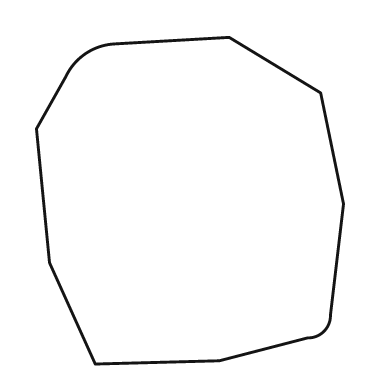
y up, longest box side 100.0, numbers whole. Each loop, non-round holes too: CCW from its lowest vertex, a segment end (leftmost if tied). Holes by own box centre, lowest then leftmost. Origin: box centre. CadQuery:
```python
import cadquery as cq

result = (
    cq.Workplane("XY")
    .moveTo(-29.0, -50.0)
    .lineTo(9.0, -49.0)
    .lineTo(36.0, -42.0)
    .threePointArc((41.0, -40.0), (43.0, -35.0))
    .lineTo(47.0, -1.0)
    .lineTo(40.0, 33.0)
    .lineTo(12.0, 50.0)
    .lineTo(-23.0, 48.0)
    .threePointArc((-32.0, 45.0), (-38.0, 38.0))
    .lineTo(-47.0, 22.0)
    .lineTo(-43.0, -19.0)
    .close()
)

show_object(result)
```